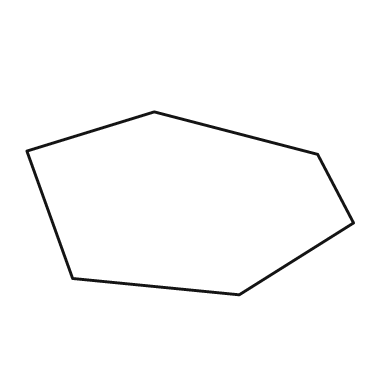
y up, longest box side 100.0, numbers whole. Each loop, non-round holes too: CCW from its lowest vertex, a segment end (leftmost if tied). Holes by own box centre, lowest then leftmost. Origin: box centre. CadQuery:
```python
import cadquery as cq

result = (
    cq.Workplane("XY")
    .moveTo(15.0, -28.0)
    .lineTo(50.0, -6.0)
    .lineTo(39.0, 15.0)
    .lineTo(-11.0, 28.0)
    .lineTo(-50.0, 16.0)
    .lineTo(-36.0, -23.0)
    .close()
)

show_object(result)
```